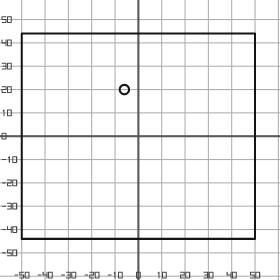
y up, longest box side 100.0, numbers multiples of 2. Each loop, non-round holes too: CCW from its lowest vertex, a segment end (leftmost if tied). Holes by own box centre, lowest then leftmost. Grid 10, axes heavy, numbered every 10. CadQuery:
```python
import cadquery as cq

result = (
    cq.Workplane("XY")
    .moveTo(-50.0, -44.0)
    .lineTo(50.0, -44.0)
    .lineTo(50.0, 44.0)
    .lineTo(-50.0, 44.0)
    .close()
    .moveTo(-6.0, 20.0)
    .circle(2.0)
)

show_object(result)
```